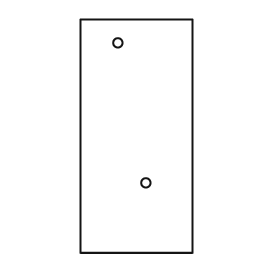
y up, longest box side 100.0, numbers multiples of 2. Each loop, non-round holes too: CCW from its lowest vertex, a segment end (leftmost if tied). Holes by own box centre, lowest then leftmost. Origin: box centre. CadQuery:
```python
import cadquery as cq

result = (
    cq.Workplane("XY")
    .moveTo(-24.0, -50.0)
    .lineTo(24.0, -50.0)
    .lineTo(24.0, 50.0)
    .lineTo(-24.0, 50.0)
    .close()
    .moveTo(4.0, -20.0)
    .circle(2.0)
    .moveTo(-8.0, 40.0)
    .circle(2.0)
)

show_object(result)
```